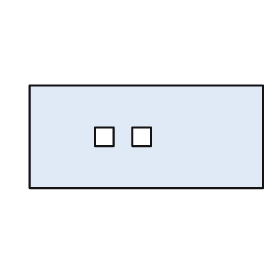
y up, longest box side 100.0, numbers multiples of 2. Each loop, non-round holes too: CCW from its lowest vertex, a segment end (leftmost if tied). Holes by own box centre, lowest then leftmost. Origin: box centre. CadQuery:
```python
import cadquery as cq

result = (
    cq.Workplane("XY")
    .moveTo(-50.0, -22.0)
    .lineTo(50.0, -22.0)
    .lineTo(50.0, 22.0)
    .lineTo(-50.0, 22.0)
    .close()
    .moveTo(-22.0, -4.0)
    .lineTo(-14.0, -4.0)
    .lineTo(-14.0, 4.0)
    .lineTo(-22.0, 4.0)
    .close()
    .moveTo(-6.0, -4.0)
    .lineTo(2.0, -4.0)
    .lineTo(2.0, 4.0)
    .lineTo(-6.0, 4.0)
    .close()
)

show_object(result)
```